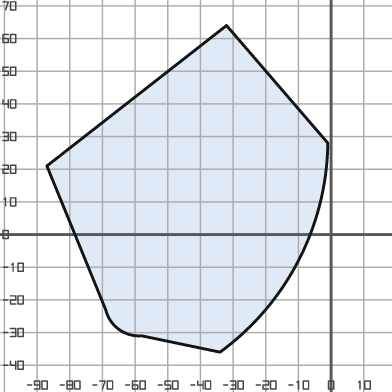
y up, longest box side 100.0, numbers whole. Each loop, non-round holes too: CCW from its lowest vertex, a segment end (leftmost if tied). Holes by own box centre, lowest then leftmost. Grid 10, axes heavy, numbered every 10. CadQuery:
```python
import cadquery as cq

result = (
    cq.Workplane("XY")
    .moveTo(-34.0, -36.0)
    .threePointArc((-10.0, -8.0), (-1.0, 28.0))
    .lineTo(-32.0, 64.0)
    .lineTo(-87.0, 21.0)
    .lineTo(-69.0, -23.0)
    .threePointArc((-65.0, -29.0), (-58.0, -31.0))
    .close()
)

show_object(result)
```